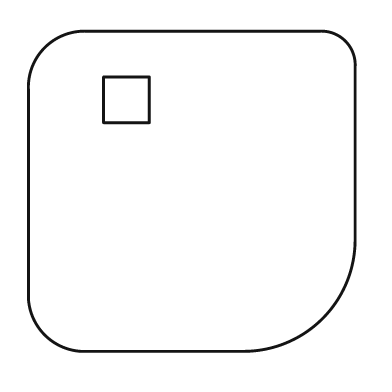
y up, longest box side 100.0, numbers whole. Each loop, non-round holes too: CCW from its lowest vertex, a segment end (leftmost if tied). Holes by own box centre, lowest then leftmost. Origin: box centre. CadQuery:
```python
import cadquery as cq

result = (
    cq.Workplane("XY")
    .moveTo(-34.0, -49.0)
    .lineTo(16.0, -49.0)
    .threePointArc((40.0, -39.0), (50.0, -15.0))
    .lineTo(50.0, 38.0)
    .threePointArc((47.0, 46.0), (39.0, 49.0))
    .lineTo(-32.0, 49.0)
    .threePointArc((-45.0, 44.0), (-50.0, 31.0))
    .lineTo(-50.0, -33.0)
    .threePointArc((-45.0, -44.0), (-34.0, -49.0))
    .close()
    .moveTo(-27.0, 21.0)
    .lineTo(-13.0, 21.0)
    .lineTo(-13.0, 35.0)
    .lineTo(-27.0, 35.0)
    .close()
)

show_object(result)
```